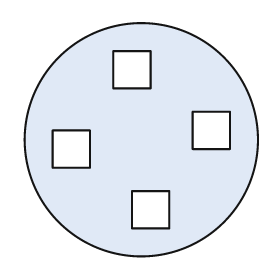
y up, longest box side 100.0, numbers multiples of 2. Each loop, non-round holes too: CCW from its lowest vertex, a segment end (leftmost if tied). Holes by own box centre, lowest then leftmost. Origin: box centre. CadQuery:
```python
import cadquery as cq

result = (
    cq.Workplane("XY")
    .moveTo(0.0, 0.0)
    .circle(50.0)
    .moveTo(-4.0, -38.0)
    .lineTo(12.0, -38.0)
    .lineTo(12.0, -22.0)
    .lineTo(-4.0, -22.0)
    .close()
    .moveTo(-38.0, -12.0)
    .lineTo(-22.0, -12.0)
    .lineTo(-22.0, 4.0)
    .lineTo(-38.0, 4.0)
    .close()
    .moveTo(22.0, -4.0)
    .lineTo(38.0, -4.0)
    .lineTo(38.0, 12.0)
    .lineTo(22.0, 12.0)
    .close()
    .moveTo(-12.0, 22.0)
    .lineTo(4.0, 22.0)
    .lineTo(4.0, 38.0)
    .lineTo(-12.0, 38.0)
    .close()
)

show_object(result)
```